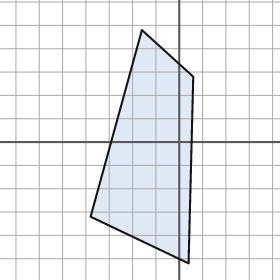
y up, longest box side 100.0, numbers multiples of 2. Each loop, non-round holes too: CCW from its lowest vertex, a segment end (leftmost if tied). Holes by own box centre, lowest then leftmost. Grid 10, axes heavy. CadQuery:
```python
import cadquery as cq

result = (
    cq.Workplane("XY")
    .moveTo(4.0, -52.0)
    .lineTo(6.0, 28.0)
    .lineTo(-16.0, 48.0)
    .lineTo(-38.0, -32.0)
    .close()
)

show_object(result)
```